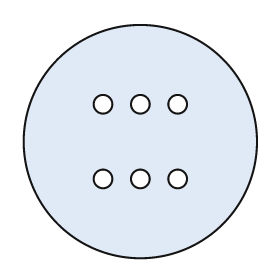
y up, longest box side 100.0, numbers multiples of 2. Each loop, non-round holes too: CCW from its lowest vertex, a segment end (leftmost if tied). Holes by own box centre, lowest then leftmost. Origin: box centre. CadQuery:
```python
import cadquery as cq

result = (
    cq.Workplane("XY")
    .moveTo(0.0, 0.0)
    .circle(50.0)
    .moveTo(-16.0, -16.0)
    .circle(4.0)
    .moveTo(0.0, -16.0)
    .circle(4.0)
    .moveTo(16.0, -16.0)
    .circle(4.0)
    .moveTo(-16.0, 16.0)
    .circle(4.0)
    .moveTo(0.0, 16.0)
    .circle(4.0)
    .moveTo(16.0, 16.0)
    .circle(4.0)
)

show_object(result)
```